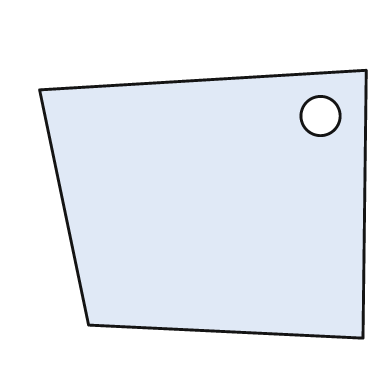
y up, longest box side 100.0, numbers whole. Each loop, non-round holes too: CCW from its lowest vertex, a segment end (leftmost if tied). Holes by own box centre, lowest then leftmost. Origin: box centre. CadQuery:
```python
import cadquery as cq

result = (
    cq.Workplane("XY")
    .moveTo(49.0, -41.0)
    .lineTo(50.0, 41.0)
    .lineTo(-50.0, 35.0)
    .lineTo(-35.0, -37.0)
    .close()
    .moveTo(36.0, 27.0)
    .circle(6.0)
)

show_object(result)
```